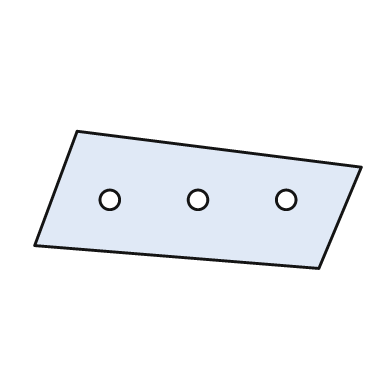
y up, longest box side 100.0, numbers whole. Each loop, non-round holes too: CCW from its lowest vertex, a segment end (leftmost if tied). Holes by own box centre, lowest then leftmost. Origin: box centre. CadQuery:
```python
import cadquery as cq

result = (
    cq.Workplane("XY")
    .moveTo(37.0, -21.0)
    .lineTo(50.0, 10.0)
    .lineTo(-37.0, 21.0)
    .lineTo(-50.0, -14.0)
    .close()
    .moveTo(-27.0, 0.0)
    .circle(3.0)
    .moveTo(0.0, 0.0)
    .circle(3.0)
    .moveTo(27.0, 0.0)
    .circle(3.0)
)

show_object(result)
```